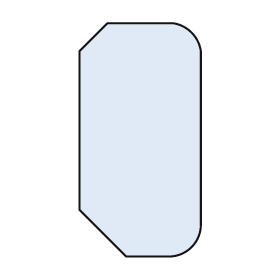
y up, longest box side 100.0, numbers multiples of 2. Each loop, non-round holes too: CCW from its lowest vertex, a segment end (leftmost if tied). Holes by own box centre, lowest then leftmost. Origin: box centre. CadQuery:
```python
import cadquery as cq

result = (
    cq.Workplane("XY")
    .moveTo(-6.0, -50.0)
    .lineTo(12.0, -50.0)
    .threePointArc((22.0, -46.0), (26.0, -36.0))
    .lineTo(26.0, 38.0)
    .threePointArc((22.0, 46.0), (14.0, 50.0))
    .lineTo(-14.0, 50.0)
    .lineTo(-26.0, 38.0)
    .lineTo(-26.0, -30.0)
    .close()
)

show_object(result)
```